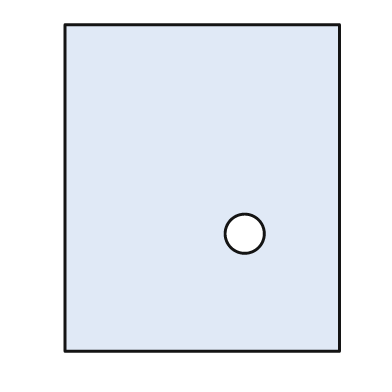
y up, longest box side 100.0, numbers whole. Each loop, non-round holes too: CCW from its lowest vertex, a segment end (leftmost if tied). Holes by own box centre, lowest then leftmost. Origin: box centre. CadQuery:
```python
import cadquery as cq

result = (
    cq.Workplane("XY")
    .moveTo(-42.0, -50.0)
    .lineTo(42.0, -50.0)
    .lineTo(42.0, 50.0)
    .lineTo(-42.0, 50.0)
    .close()
    .moveTo(13.0, -14.0)
    .circle(6.0)
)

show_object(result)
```